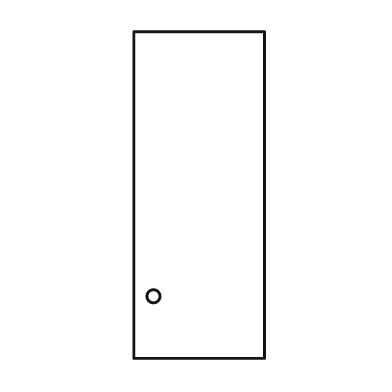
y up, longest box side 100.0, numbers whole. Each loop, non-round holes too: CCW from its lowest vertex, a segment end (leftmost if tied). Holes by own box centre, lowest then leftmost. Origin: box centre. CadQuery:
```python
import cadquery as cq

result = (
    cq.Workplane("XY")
    .moveTo(-20.0, -50.0)
    .lineTo(20.0, -50.0)
    .lineTo(20.0, 50.0)
    .lineTo(-20.0, 50.0)
    .close()
    .moveTo(-14.0, -31.0)
    .circle(2.0)
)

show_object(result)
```